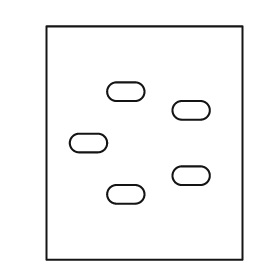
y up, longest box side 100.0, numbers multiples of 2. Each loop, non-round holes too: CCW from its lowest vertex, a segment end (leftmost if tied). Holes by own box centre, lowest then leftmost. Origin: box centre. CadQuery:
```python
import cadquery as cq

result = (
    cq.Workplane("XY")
    .moveTo(-42.0, -50.0)
    .lineTo(42.0, -50.0)
    .lineTo(42.0, 50.0)
    .lineTo(-42.0, 50.0)
    .close()
    .moveTo(-12.0, -26.0)
    .lineTo(-4.0, -26.0)
    .threePointArc((0.0, -22.0), (-4.0, -18.0))
    .lineTo(-12.0, -18.0)
    .threePointArc((-16.0, -22.0), (-12.0, -26.0))
    .close()
    .moveTo(16.0, -18.0)
    .lineTo(24.0, -18.0)
    .threePointArc((28.0, -14.0), (24.0, -10.0))
    .lineTo(16.0, -10.0)
    .threePointArc((12.0, -14.0), (16.0, -18.0))
    .close()
    .moveTo(-28.0, -4.0)
    .lineTo(-20.0, -4.0)
    .threePointArc((-16.0, 0.0), (-20.0, 4.0))
    .lineTo(-28.0, 4.0)
    .threePointArc((-32.0, 0.0), (-28.0, -4.0))
    .close()
    .moveTo(16.0, 10.0)
    .lineTo(24.0, 10.0)
    .threePointArc((28.0, 14.0), (24.0, 18.0))
    .lineTo(16.0, 18.0)
    .threePointArc((12.0, 14.0), (16.0, 10.0))
    .close()
    .moveTo(-12.0, 18.0)
    .lineTo(-4.0, 18.0)
    .threePointArc((0.0, 22.0), (-4.0, 26.0))
    .lineTo(-12.0, 26.0)
    .threePointArc((-16.0, 22.0), (-12.0, 18.0))
    .close()
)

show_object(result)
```